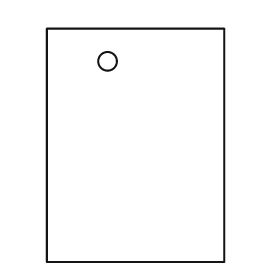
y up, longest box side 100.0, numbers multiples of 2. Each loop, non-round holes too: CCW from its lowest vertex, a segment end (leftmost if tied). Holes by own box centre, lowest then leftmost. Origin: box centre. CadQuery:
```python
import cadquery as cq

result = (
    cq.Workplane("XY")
    .moveTo(-38.0, -50.0)
    .lineTo(38.0, -50.0)
    .lineTo(38.0, 50.0)
    .lineTo(-38.0, 50.0)
    .close()
    .moveTo(-12.0, 36.0)
    .circle(4.0)
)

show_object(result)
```